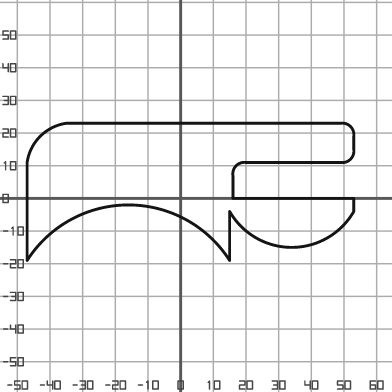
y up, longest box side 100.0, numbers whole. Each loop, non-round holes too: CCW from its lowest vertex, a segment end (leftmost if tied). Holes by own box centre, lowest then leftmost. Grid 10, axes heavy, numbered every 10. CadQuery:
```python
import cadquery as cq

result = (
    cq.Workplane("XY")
    .moveTo(-47.0, -19.0)
    .threePointArc((-16.0, -2.0), (15.0, -19.0))
    .lineTo(15.0, -4.0)
    .threePointArc((34.0, -15.0), (53.0, -4.0))
    .lineTo(53.0, 0.0)
    .lineTo(16.0, 0.0)
    .lineTo(16.0, 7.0)
    .threePointArc((17.0, 10.0), (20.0, 11.0))
    .lineTo(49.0, 11.0)
    .threePointArc((52.0, 12.0), (53.0, 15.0))
    .lineTo(53.0, 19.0)
    .threePointArc((52.0, 22.0), (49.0, 23.0))
    .lineTo(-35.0, 23.0)
    .threePointArc((-43.0, 19.0), (-47.0, 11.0))
    .close()
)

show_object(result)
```